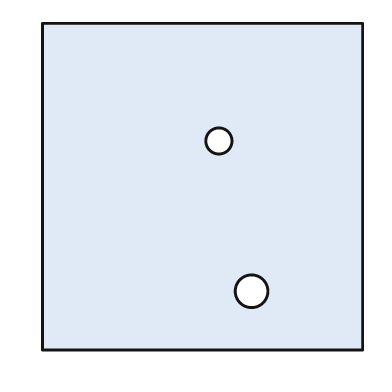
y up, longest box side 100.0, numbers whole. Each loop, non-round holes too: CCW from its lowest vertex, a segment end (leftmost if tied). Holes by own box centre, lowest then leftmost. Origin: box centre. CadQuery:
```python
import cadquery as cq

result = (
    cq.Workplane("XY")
    .moveTo(-49.0, -50.0)
    .lineTo(49.0, -50.0)
    .lineTo(49.0, 50.0)
    .lineTo(-49.0, 50.0)
    .close()
    .moveTo(15.0, -32.0)
    .circle(5.0)
    .moveTo(5.0, 14.0)
    .circle(4.0)
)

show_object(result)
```